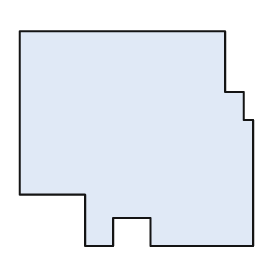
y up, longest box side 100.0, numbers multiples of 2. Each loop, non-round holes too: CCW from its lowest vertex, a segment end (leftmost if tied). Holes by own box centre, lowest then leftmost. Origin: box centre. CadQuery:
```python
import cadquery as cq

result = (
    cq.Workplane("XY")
    .moveTo(-22.0, -46.0)
    .lineTo(-10.0, -46.0)
    .lineTo(-10.0, -34.0)
    .lineTo(6.0, -34.0)
    .lineTo(6.0, -46.0)
    .lineTo(50.0, -46.0)
    .lineTo(50.0, 8.0)
    .lineTo(46.0, 8.0)
    .lineTo(46.0, 20.0)
    .lineTo(38.0, 20.0)
    .lineTo(38.0, 46.0)
    .lineTo(-50.0, 46.0)
    .lineTo(-50.0, -24.0)
    .lineTo(-22.0, -24.0)
    .close()
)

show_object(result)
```